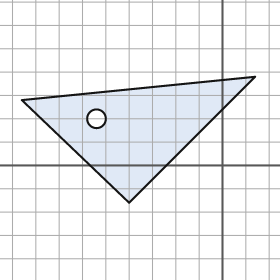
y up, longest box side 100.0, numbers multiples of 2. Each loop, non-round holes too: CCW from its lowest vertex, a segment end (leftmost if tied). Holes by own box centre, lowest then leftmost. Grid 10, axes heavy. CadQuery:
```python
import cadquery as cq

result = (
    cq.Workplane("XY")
    .moveTo(-40.0, -16.0)
    .lineTo(14.0, 38.0)
    .lineTo(-86.0, 28.0)
    .close()
    .moveTo(-54.0, 20.0)
    .circle(4.0)
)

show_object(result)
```